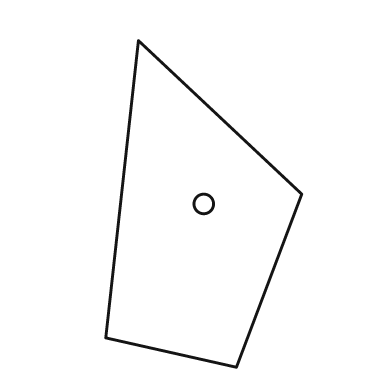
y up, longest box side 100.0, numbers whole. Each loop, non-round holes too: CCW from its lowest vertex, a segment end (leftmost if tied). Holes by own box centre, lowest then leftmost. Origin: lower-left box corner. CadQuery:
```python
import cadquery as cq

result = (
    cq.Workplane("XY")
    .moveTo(40.0, 0.0)
    .lineTo(60.0, 53.0)
    .lineTo(10.0, 100.0)
    .lineTo(0.0, 9.0)
    .close()
    .moveTo(30.0, 50.0)
    .circle(3.0)
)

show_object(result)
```